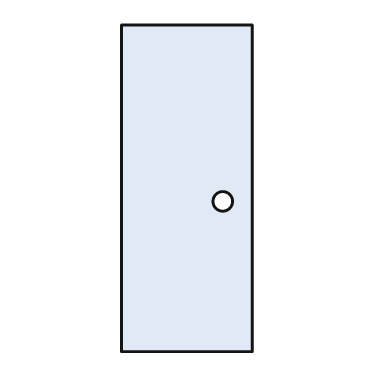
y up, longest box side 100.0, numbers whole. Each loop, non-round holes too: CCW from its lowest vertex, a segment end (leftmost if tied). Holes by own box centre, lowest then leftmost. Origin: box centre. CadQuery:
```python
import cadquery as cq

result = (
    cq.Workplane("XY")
    .moveTo(-20.0, -50.0)
    .lineTo(20.0, -50.0)
    .lineTo(20.0, 50.0)
    .lineTo(-20.0, 50.0)
    .close()
    .moveTo(11.0, -4.0)
    .circle(3.0)
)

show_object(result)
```